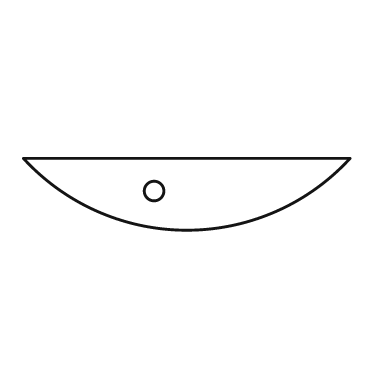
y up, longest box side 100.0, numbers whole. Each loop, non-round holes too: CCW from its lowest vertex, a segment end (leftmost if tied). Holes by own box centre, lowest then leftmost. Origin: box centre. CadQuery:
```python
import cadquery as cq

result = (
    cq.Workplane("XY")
    .moveTo(-50.0, 11.0)
    .threePointArc((0.0, -11.0), (50.0, 11.0))
    .close()
    .moveTo(-10.0, 1.0)
    .circle(3.0)
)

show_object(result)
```